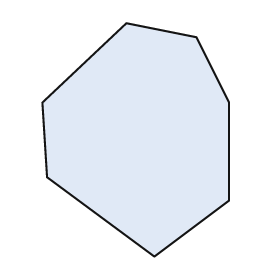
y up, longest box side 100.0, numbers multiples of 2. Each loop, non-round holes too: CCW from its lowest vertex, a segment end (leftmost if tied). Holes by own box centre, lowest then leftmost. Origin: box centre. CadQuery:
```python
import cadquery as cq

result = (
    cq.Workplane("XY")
    .moveTo(8.0, -50.0)
    .lineTo(40.0, -26.0)
    .lineTo(40.0, 16.0)
    .lineTo(26.0, 44.0)
    .lineTo(-4.0, 50.0)
    .lineTo(-40.0, 16.0)
    .lineTo(-38.0, -16.0)
    .close()
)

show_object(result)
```